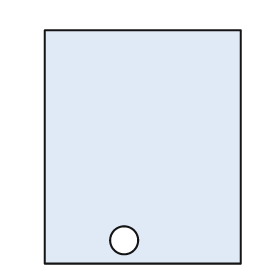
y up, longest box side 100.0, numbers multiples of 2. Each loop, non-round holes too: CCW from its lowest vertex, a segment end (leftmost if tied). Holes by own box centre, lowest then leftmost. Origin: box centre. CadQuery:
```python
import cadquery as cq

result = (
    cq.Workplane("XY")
    .moveTo(-42.0, -50.0)
    .lineTo(42.0, -50.0)
    .lineTo(42.0, 50.0)
    .lineTo(-42.0, 50.0)
    .close()
    .moveTo(-8.0, -40.0)
    .circle(6.0)
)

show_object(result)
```